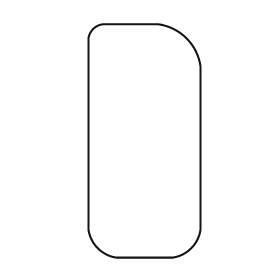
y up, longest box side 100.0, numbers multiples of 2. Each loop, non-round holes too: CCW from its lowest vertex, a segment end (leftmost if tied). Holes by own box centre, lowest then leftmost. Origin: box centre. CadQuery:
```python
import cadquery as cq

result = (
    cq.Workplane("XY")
    .moveTo(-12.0, -50.0)
    .lineTo(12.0, -50.0)
    .threePointArc((20.0, -46.0), (24.0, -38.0))
    .lineTo(24.0, 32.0)
    .threePointArc((18.0, 44.0), (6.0, 50.0))
    .lineTo(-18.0, 50.0)
    .threePointArc((-22.0, 48.0), (-24.0, 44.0))
    .lineTo(-24.0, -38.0)
    .threePointArc((-20.0, -46.0), (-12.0, -50.0))
    .close()
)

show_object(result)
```